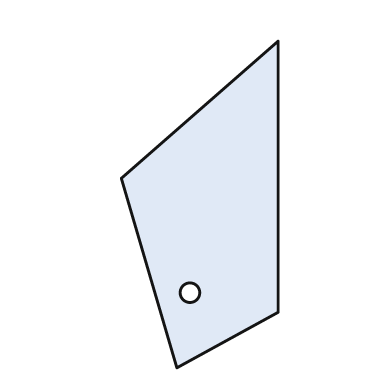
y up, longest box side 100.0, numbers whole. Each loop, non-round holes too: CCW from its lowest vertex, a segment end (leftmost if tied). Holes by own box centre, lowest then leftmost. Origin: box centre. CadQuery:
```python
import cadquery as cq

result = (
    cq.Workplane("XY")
    .moveTo(-7.0, -50.0)
    .lineTo(24.0, -33.0)
    .lineTo(24.0, 50.0)
    .lineTo(-24.0, 8.0)
    .close()
    .moveTo(-3.0, -27.0)
    .circle(3.0)
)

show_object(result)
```